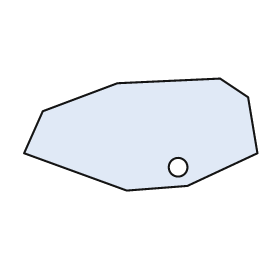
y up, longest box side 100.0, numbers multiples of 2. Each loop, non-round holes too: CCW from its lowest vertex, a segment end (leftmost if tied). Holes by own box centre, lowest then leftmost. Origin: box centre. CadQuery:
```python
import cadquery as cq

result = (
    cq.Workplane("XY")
    .moveTo(-6.0, -24.0)
    .lineTo(20.0, -22.0)
    .lineTo(50.0, -8.0)
    .lineTo(46.0, 16.0)
    .lineTo(34.0, 24.0)
    .lineTo(-10.0, 22.0)
    .lineTo(-42.0, 10.0)
    .lineTo(-50.0, -8.0)
    .close()
    .moveTo(16.0, -14.0)
    .circle(4.0)
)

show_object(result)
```